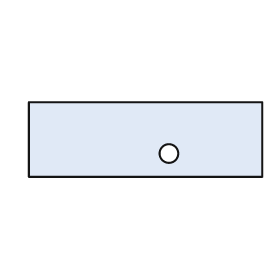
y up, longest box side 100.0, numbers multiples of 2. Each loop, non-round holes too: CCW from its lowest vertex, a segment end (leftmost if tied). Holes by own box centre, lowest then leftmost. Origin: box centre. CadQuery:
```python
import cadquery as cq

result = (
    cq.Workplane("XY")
    .moveTo(-50.0, -16.0)
    .lineTo(50.0, -16.0)
    .lineTo(50.0, 16.0)
    .lineTo(-50.0, 16.0)
    .close()
    .moveTo(10.0, -6.0)
    .circle(4.0)
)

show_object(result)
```